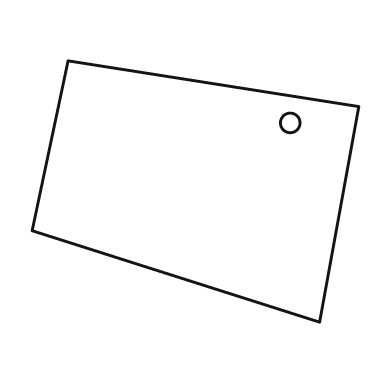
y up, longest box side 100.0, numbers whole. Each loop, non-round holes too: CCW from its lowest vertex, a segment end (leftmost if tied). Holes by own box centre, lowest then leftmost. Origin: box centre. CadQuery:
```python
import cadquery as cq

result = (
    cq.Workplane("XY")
    .moveTo(38.0, -40.0)
    .lineTo(50.0, 26.0)
    .lineTo(-39.0, 40.0)
    .lineTo(-50.0, -12.0)
    .close()
    .moveTo(29.0, 21.0)
    .circle(3.0)
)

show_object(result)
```